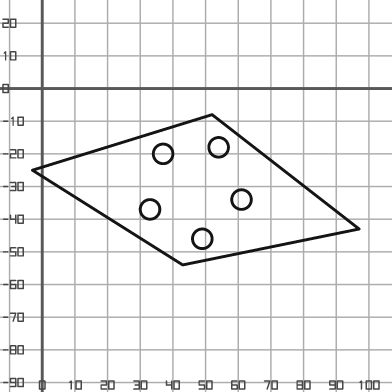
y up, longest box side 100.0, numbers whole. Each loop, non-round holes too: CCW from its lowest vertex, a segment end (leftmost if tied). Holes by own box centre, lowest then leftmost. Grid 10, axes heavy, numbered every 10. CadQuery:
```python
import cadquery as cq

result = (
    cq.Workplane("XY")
    .moveTo(43.0, -54.0)
    .lineTo(97.0, -43.0)
    .lineTo(52.0, -8.0)
    .lineTo(-3.0, -25.0)
    .close()
    .moveTo(49.0, -46.0)
    .circle(3.0)
    .moveTo(33.0, -37.0)
    .circle(3.0)
    .moveTo(61.0, -34.0)
    .circle(3.0)
    .moveTo(37.0, -20.0)
    .circle(3.0)
    .moveTo(54.0, -18.0)
    .circle(3.0)
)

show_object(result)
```